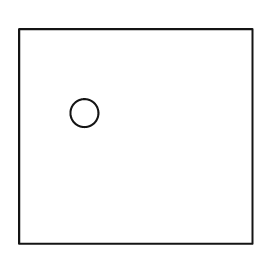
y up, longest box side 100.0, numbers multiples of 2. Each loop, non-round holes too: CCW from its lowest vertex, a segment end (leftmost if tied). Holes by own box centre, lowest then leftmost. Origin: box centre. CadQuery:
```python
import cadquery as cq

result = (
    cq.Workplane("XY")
    .moveTo(-50.0, -46.0)
    .lineTo(50.0, -46.0)
    .lineTo(50.0, 46.0)
    .lineTo(-50.0, 46.0)
    .close()
    .moveTo(-22.0, 10.0)
    .circle(6.0)
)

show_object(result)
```